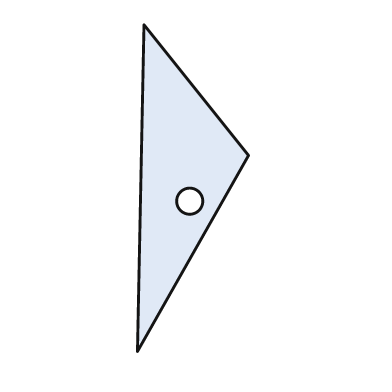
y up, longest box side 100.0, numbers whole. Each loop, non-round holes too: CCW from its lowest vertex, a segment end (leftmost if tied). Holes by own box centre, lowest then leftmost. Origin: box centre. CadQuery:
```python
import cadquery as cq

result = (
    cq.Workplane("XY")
    .moveTo(-17.0, -50.0)
    .lineTo(17.0, 10.0)
    .lineTo(-15.0, 50.0)
    .close()
    .moveTo(-1.0, -4.0)
    .circle(4.0)
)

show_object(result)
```